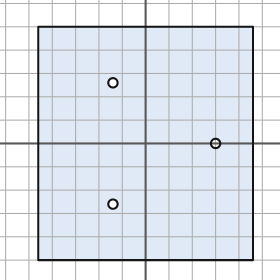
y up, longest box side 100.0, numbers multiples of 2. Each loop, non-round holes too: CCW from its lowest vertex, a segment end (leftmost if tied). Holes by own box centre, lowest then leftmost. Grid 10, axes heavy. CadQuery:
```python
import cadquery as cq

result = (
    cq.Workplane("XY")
    .moveTo(-46.0, -50.0)
    .lineTo(46.0, -50.0)
    .lineTo(46.0, 50.0)
    .lineTo(-46.0, 50.0)
    .close()
    .moveTo(-14.0, -26.0)
    .circle(2.0)
    .moveTo(30.0, 0.0)
    .circle(2.0)
    .moveTo(-14.0, 26.0)
    .circle(2.0)
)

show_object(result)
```